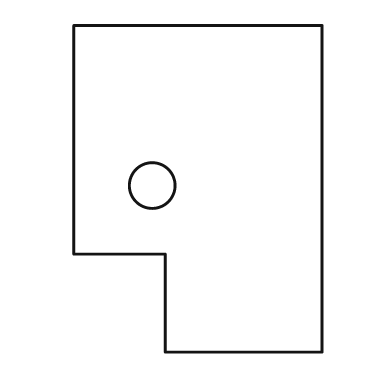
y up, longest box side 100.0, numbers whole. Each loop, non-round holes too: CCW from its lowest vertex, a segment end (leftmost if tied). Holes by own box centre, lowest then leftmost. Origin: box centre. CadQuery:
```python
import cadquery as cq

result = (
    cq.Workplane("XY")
    .moveTo(-10.0, -50.0)
    .lineTo(38.0, -50.0)
    .lineTo(38.0, 50.0)
    .lineTo(-38.0, 50.0)
    .lineTo(-38.0, -20.0)
    .lineTo(-10.0, -20.0)
    .close()
    .moveTo(-14.0, 1.0)
    .circle(7.0)
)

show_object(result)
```